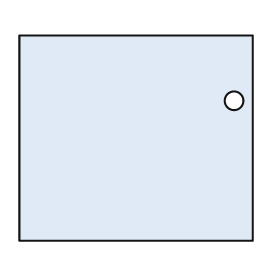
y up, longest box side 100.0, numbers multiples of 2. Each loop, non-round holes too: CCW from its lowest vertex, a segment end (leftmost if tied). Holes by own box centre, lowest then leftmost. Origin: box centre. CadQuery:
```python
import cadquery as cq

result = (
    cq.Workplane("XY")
    .moveTo(-50.0, -44.0)
    .lineTo(50.0, -44.0)
    .lineTo(50.0, 44.0)
    .lineTo(-50.0, 44.0)
    .close()
    .moveTo(42.0, 16.0)
    .circle(4.0)
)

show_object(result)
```